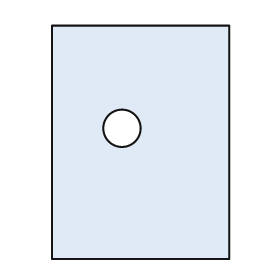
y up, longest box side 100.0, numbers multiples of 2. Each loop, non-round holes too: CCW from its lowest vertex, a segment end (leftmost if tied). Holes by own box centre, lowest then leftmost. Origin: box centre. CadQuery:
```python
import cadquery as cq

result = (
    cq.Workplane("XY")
    .moveTo(-38.0, -50.0)
    .lineTo(38.0, -50.0)
    .lineTo(38.0, 50.0)
    .lineTo(-38.0, 50.0)
    .close()
    .moveTo(-8.0, 6.0)
    .circle(8.0)
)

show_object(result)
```